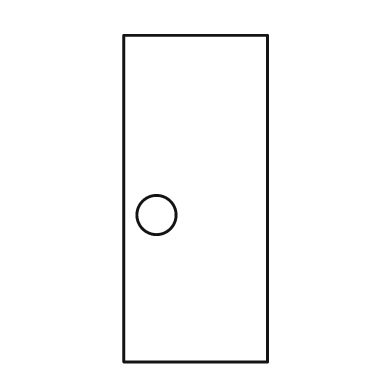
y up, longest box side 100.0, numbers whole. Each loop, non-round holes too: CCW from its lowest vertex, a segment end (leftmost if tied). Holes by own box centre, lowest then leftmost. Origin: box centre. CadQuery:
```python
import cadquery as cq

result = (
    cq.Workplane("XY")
    .moveTo(-22.0, -50.0)
    .lineTo(22.0, -50.0)
    .lineTo(22.0, 50.0)
    .lineTo(-22.0, 50.0)
    .close()
    .moveTo(-12.0, -5.0)
    .circle(6.0)
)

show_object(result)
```